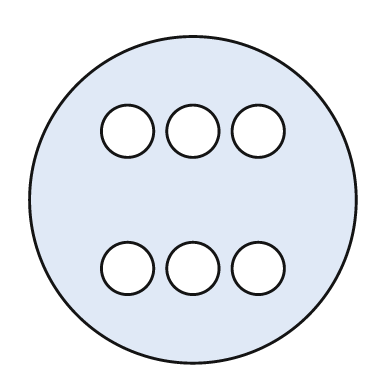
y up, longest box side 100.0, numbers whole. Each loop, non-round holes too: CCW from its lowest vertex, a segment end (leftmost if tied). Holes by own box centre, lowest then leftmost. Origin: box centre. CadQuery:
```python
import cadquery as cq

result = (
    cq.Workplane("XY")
    .moveTo(0.0, 0.0)
    .circle(50.0)
    .moveTo(-20.0, -21.0)
    .circle(8.0)
    .moveTo(0.0, -21.0)
    .circle(8.0)
    .moveTo(20.0, -21.0)
    .circle(8.0)
    .moveTo(-20.0, 21.0)
    .circle(8.0)
    .moveTo(0.0, 21.0)
    .circle(8.0)
    .moveTo(20.0, 21.0)
    .circle(8.0)
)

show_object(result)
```